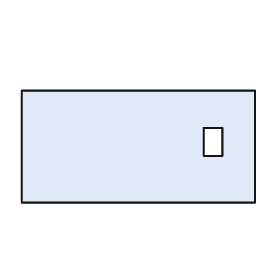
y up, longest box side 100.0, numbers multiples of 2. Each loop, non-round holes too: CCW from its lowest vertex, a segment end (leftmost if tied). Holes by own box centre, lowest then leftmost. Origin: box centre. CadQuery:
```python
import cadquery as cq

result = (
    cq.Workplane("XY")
    .moveTo(-50.0, -24.0)
    .lineTo(50.0, -24.0)
    .lineTo(50.0, 24.0)
    .lineTo(-50.0, 24.0)
    .close()
    .moveTo(28.0, -4.0)
    .lineTo(36.0, -4.0)
    .lineTo(36.0, 8.0)
    .lineTo(28.0, 8.0)
    .close()
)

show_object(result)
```